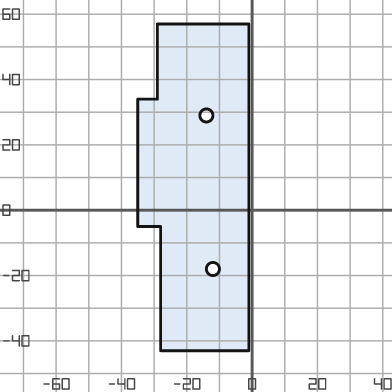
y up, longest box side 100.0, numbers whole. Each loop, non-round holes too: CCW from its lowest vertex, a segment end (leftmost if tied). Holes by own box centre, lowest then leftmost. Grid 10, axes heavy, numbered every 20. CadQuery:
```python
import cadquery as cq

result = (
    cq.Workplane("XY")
    .moveTo(-28.0, -43.0)
    .lineTo(-1.0, -43.0)
    .lineTo(-1.0, 57.0)
    .lineTo(-29.0, 57.0)
    .lineTo(-29.0, 34.0)
    .lineTo(-35.0, 34.0)
    .lineTo(-35.0, -5.0)
    .lineTo(-28.0, -5.0)
    .close()
    .moveTo(-12.0, -18.0)
    .circle(2.0)
    .moveTo(-14.0, 29.0)
    .circle(2.0)
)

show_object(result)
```